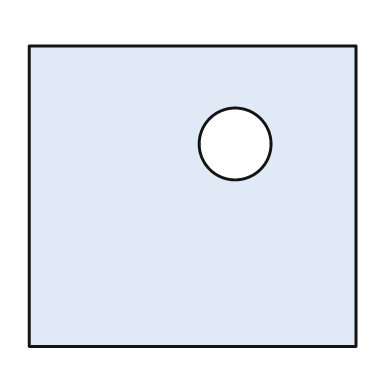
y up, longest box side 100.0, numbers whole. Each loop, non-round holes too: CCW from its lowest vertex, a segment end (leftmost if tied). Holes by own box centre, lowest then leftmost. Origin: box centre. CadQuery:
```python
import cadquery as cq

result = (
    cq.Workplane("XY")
    .moveTo(-50.0, -46.0)
    .lineTo(50.0, -46.0)
    .lineTo(50.0, 46.0)
    .lineTo(-50.0, 46.0)
    .close()
    .moveTo(13.0, 16.0)
    .circle(11.0)
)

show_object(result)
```